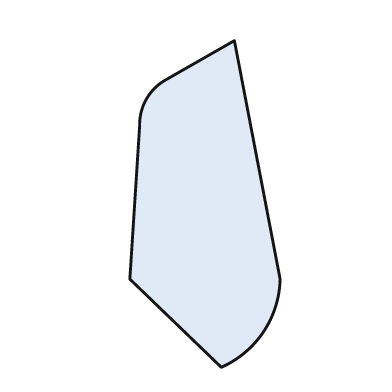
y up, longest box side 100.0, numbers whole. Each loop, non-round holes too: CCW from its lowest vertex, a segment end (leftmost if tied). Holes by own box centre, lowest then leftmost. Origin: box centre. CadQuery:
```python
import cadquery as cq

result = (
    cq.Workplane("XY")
    .moveTo(5.0, -50.0)
    .threePointArc((18.0, -39.0), (23.0, -23.0))
    .lineTo(9.0, 50.0)
    .lineTo(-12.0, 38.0)
    .threePointArc((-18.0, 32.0), (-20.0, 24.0))
    .lineTo(-23.0, -23.0)
    .close()
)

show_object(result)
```